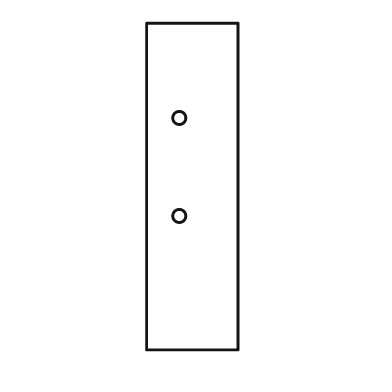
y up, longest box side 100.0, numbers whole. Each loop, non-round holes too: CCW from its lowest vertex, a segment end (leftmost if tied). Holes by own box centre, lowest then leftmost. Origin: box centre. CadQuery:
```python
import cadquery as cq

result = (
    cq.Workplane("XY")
    .moveTo(-14.0, -50.0)
    .lineTo(14.0, -50.0)
    .lineTo(14.0, 50.0)
    .lineTo(-14.0, 50.0)
    .close()
    .moveTo(-4.0, -9.0)
    .circle(2.0)
    .moveTo(-4.0, 21.0)
    .circle(2.0)
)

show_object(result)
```